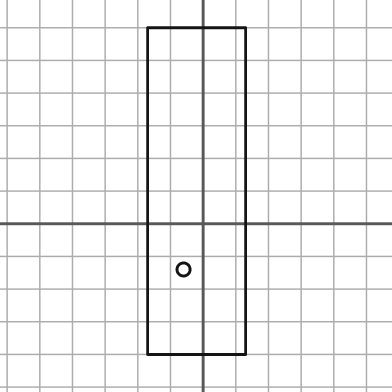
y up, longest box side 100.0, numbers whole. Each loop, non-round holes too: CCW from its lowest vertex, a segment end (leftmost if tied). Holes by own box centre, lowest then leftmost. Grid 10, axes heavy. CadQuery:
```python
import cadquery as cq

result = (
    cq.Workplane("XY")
    .moveTo(-17.0, -40.0)
    .lineTo(13.0, -40.0)
    .lineTo(13.0, 60.0)
    .lineTo(-17.0, 60.0)
    .close()
    .moveTo(-6.0, -14.0)
    .circle(2.0)
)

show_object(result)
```